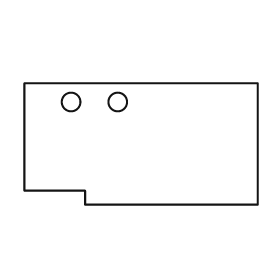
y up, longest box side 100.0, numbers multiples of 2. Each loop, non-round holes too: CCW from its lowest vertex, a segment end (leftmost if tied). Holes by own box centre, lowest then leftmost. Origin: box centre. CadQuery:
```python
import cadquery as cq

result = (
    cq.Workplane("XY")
    .moveTo(-24.0, -26.0)
    .lineTo(50.0, -26.0)
    .lineTo(50.0, 26.0)
    .lineTo(-50.0, 26.0)
    .lineTo(-50.0, -20.0)
    .lineTo(-24.0, -20.0)
    .close()
    .moveTo(-30.0, 18.0)
    .circle(4.0)
    .moveTo(-10.0, 18.0)
    .circle(4.0)
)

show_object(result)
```